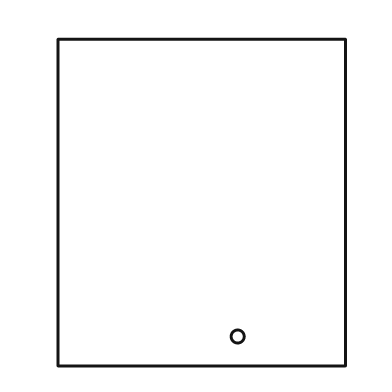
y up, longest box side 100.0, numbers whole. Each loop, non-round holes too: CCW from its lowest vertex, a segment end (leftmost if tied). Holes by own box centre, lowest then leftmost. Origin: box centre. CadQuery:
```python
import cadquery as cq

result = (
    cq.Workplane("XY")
    .moveTo(-44.0, -50.0)
    .lineTo(44.0, -50.0)
    .lineTo(44.0, 50.0)
    .lineTo(-44.0, 50.0)
    .close()
    .moveTo(11.0, -41.0)
    .circle(2.0)
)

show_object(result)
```